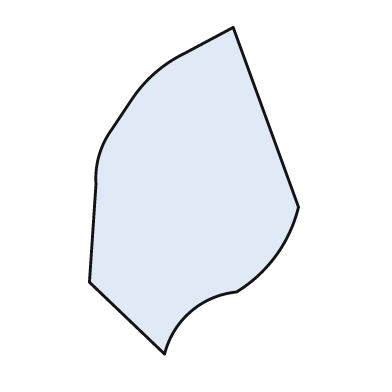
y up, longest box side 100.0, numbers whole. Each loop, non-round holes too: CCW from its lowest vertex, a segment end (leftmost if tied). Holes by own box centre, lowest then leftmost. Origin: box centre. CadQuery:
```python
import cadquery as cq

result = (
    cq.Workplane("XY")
    .moveTo(-9.0, -50.0)
    .threePointArc((-1.0, -37.0), (13.0, -31.0))
    .threePointArc((25.0, -20.0), (32.0, -5.0))
    .lineTo(12.0, 50.0)
    .lineTo(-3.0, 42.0)
    .threePointArc((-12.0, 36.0), (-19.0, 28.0))
    .lineTo(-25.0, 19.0)
    .threePointArc((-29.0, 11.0), (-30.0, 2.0))
    .lineTo(-32.0, -28.0)
    .close()
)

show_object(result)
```